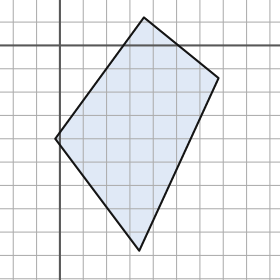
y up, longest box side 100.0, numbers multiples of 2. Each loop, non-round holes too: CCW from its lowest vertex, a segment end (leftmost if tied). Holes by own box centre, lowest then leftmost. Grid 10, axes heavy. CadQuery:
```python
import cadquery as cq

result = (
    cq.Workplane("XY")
    .moveTo(34.0, -88.0)
    .lineTo(68.0, -14.0)
    .lineTo(36.0, 12.0)
    .lineTo(-2.0, -40.0)
    .close()
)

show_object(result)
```